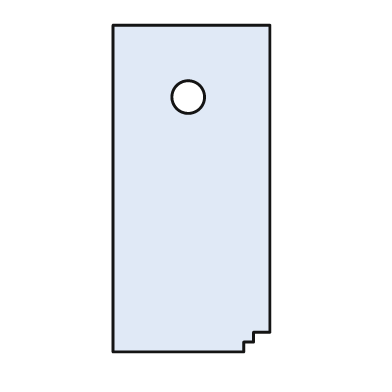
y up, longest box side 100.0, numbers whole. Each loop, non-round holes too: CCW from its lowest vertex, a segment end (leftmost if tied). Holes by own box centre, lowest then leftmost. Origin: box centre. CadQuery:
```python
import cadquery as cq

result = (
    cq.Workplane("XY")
    .moveTo(-24.0, -50.0)
    .lineTo(16.0, -50.0)
    .lineTo(16.0, -47.0)
    .lineTo(19.0, -47.0)
    .lineTo(19.0, -44.0)
    .lineTo(24.0, -44.0)
    .lineTo(24.0, 50.0)
    .lineTo(-24.0, 50.0)
    .close()
    .moveTo(-1.0, 28.0)
    .circle(5.0)
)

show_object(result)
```